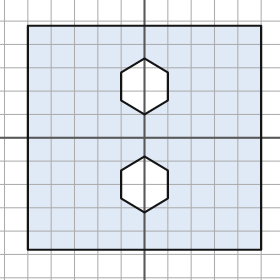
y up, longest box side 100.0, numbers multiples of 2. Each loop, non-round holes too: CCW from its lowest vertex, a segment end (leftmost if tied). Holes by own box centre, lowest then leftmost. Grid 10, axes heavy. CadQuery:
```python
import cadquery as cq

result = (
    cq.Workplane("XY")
    .moveTo(-50.0, -48.0)
    .lineTo(50.0, -48.0)
    .lineTo(50.0, 48.0)
    .lineTo(-50.0, 48.0)
    .close()
    .moveTo(0.0, -32.0)
    .lineTo(10.0, -26.0)
    .lineTo(10.0, -14.0)
    .lineTo(0.0, -8.0)
    .lineTo(-10.0, -14.0)
    .lineTo(-10.0, -26.0)
    .close()
    .moveTo(0.0, 10.0)
    .lineTo(10.0, 16.0)
    .lineTo(10.0, 28.0)
    .lineTo(0.0, 34.0)
    .lineTo(-10.0, 28.0)
    .lineTo(-10.0, 16.0)
    .close()
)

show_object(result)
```